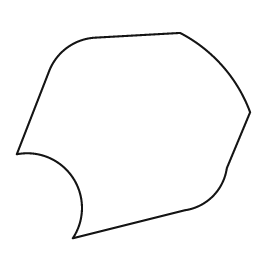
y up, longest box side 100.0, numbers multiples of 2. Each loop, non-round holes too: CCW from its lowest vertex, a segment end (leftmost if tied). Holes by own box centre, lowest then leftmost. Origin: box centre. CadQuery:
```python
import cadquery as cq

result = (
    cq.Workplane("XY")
    .moveTo(-26.0, -44.0)
    .lineTo(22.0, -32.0)
    .threePointArc((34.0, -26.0), (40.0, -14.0))
    .lineTo(50.0, 10.0)
    .threePointArc((38.0, 30.0), (20.0, 44.0))
    .lineTo(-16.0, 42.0)
    .threePointArc((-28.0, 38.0), (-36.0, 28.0))
    .lineTo(-50.0, -8.0)
    .threePointArc((-26.0, -18.0), (-26.0, -44.0))
    .close()
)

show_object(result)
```